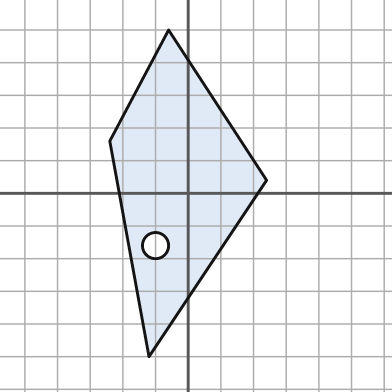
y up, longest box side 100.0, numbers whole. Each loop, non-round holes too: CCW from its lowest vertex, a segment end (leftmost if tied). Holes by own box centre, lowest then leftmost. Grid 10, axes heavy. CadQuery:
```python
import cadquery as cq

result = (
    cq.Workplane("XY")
    .moveTo(-12.0, -50.0)
    .lineTo(24.0, 4.0)
    .lineTo(-6.0, 50.0)
    .lineTo(-24.0, 16.0)
    .close()
    .moveTo(-10.0, -16.0)
    .circle(4.0)
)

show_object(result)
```